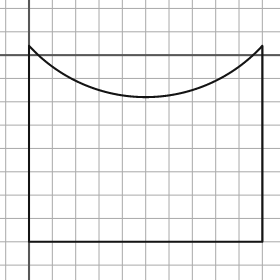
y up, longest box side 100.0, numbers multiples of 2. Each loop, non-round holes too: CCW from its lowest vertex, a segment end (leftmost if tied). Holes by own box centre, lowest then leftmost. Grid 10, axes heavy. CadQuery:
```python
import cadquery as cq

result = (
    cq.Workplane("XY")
    .moveTo(0.0, -80.0)
    .lineTo(100.0, -80.0)
    .lineTo(100.0, 4.0)
    .threePointArc((50.0, -18.0), (0.0, 4.0))
    .close()
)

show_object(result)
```